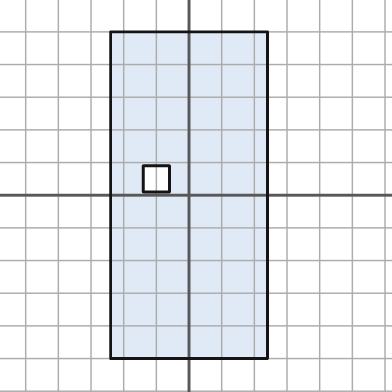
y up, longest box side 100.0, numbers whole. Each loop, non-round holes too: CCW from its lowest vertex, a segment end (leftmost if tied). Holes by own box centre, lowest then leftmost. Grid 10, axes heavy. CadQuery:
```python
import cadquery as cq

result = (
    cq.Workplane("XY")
    .moveTo(-24.0, -50.0)
    .lineTo(24.0, -50.0)
    .lineTo(24.0, 50.0)
    .lineTo(-24.0, 50.0)
    .close()
    .moveTo(-14.0, 1.0)
    .lineTo(-6.0, 1.0)
    .lineTo(-6.0, 9.0)
    .lineTo(-14.0, 9.0)
    .close()
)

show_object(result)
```